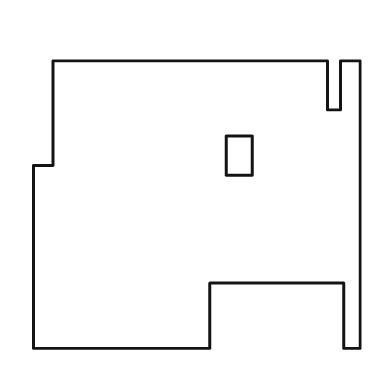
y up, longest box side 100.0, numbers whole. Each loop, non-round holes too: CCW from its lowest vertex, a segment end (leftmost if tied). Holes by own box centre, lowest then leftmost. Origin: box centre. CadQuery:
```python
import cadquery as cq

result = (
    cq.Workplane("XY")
    .moveTo(-50.0, -44.0)
    .lineTo(4.0, -44.0)
    .lineTo(4.0, -24.0)
    .lineTo(45.0, -24.0)
    .lineTo(45.0, -44.0)
    .lineTo(50.0, -44.0)
    .lineTo(50.0, 44.0)
    .lineTo(44.0, 44.0)
    .lineTo(44.0, 29.0)
    .lineTo(40.0, 29.0)
    .lineTo(40.0, 44.0)
    .lineTo(-44.0, 44.0)
    .lineTo(-44.0, 12.0)
    .lineTo(-50.0, 12.0)
    .close()
    .moveTo(9.0, 9.0)
    .lineTo(17.0, 9.0)
    .lineTo(17.0, 21.0)
    .lineTo(9.0, 21.0)
    .close()
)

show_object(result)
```